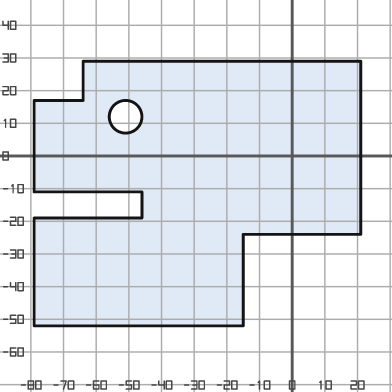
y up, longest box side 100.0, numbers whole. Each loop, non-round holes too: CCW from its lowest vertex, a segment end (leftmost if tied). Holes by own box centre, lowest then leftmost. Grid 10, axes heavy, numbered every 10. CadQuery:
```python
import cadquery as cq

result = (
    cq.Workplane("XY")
    .moveTo(-79.0, -52.0)
    .lineTo(-15.0, -52.0)
    .lineTo(-15.0, -24.0)
    .lineTo(21.0, -24.0)
    .lineTo(21.0, 29.0)
    .lineTo(-64.0, 29.0)
    .lineTo(-64.0, 17.0)
    .lineTo(-79.0, 17.0)
    .lineTo(-79.0, -11.0)
    .lineTo(-46.0, -11.0)
    .lineTo(-46.0, -19.0)
    .lineTo(-79.0, -19.0)
    .close()
    .moveTo(-51.0, 12.0)
    .circle(5.0)
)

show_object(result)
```